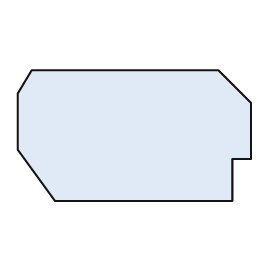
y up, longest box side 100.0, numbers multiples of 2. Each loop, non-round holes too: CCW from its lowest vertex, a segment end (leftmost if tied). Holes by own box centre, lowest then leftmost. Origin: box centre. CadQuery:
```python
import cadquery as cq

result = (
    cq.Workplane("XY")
    .moveTo(-34.0, -28.0)
    .lineTo(42.0, -28.0)
    .lineTo(42.0, -10.0)
    .lineTo(50.0, -10.0)
    .lineTo(50.0, 14.0)
    .lineTo(36.0, 28.0)
    .lineTo(-44.0, 28.0)
    .lineTo(-50.0, 18.0)
    .lineTo(-50.0, -6.0)
    .close()
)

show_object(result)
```